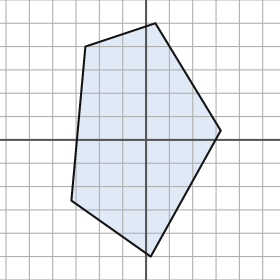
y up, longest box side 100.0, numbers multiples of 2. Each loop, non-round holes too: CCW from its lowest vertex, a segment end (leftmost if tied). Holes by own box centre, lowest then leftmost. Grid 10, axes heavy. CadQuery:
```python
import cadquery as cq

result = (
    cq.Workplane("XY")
    .moveTo(2.0, -50.0)
    .lineTo(32.0, 4.0)
    .lineTo(4.0, 50.0)
    .lineTo(-26.0, 40.0)
    .lineTo(-32.0, -26.0)
    .close()
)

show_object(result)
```